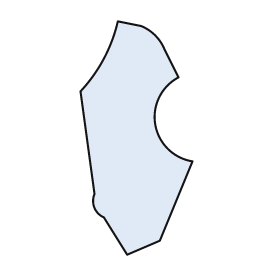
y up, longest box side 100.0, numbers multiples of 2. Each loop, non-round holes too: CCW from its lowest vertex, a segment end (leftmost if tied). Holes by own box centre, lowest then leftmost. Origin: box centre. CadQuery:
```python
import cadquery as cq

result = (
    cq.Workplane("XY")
    .moveTo(-4.0, -50.0)
    .lineTo(10.0, -44.0)
    .lineTo(24.0, -10.0)
    .threePointArc((8.0, 6.0), (18.0, 26.0))
    .lineTo(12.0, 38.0)
    .threePointArc((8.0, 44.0), (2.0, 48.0))
    .lineTo(-8.0, 50.0)
    .threePointArc((-14.0, 34.0), (-24.0, 20.0))
    .lineTo(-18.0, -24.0)
    .threePointArc((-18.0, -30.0), (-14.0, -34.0))
    .close()
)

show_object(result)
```